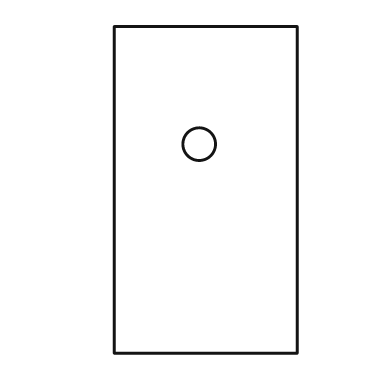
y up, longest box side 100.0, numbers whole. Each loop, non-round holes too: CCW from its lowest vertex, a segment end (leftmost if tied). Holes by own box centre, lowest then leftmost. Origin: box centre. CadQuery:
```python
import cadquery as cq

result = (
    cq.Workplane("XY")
    .moveTo(-28.0, -50.0)
    .lineTo(28.0, -50.0)
    .lineTo(28.0, 50.0)
    .lineTo(-28.0, 50.0)
    .close()
    .moveTo(-2.0, 14.0)
    .circle(5.0)
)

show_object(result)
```